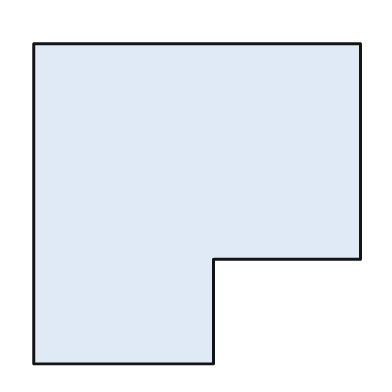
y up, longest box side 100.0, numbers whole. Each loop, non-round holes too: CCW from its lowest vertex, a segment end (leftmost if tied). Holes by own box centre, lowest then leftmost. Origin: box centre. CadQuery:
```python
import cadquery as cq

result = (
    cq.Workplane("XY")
    .moveTo(-50.0, -49.0)
    .lineTo(5.0, -49.0)
    .lineTo(5.0, -17.0)
    .lineTo(50.0, -17.0)
    .lineTo(50.0, 49.0)
    .lineTo(-50.0, 49.0)
    .close()
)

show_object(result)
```